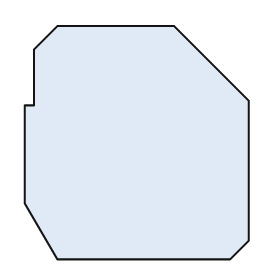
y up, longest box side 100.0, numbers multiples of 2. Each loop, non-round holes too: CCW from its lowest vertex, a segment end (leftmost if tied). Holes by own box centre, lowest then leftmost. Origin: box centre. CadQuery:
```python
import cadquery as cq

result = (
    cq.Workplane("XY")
    .moveTo(-34.0, -50.0)
    .lineTo(40.0, -50.0)
    .lineTo(48.0, -42.0)
    .lineTo(48.0, 18.0)
    .lineTo(16.0, 50.0)
    .lineTo(-34.0, 50.0)
    .lineTo(-44.0, 40.0)
    .lineTo(-44.0, 16.0)
    .lineTo(-48.0, 16.0)
    .lineTo(-48.0, -26.0)
    .close()
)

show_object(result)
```